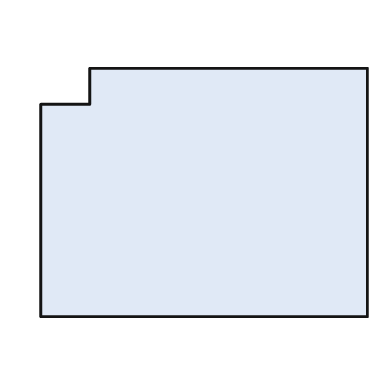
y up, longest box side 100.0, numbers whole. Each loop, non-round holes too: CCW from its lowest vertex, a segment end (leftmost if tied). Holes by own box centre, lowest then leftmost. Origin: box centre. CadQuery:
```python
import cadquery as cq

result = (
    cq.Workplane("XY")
    .moveTo(-50.0, -38.0)
    .lineTo(50.0, -38.0)
    .lineTo(50.0, 38.0)
    .lineTo(-35.0, 38.0)
    .lineTo(-35.0, 27.0)
    .lineTo(-50.0, 27.0)
    .close()
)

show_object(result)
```